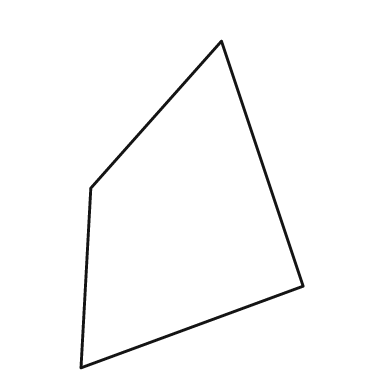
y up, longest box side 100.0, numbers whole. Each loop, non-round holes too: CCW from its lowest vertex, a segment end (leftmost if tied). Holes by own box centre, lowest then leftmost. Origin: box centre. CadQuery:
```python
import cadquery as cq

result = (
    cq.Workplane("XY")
    .moveTo(-34.0, -50.0)
    .lineTo(34.0, -25.0)
    .lineTo(9.0, 50.0)
    .lineTo(-31.0, 5.0)
    .close()
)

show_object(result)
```